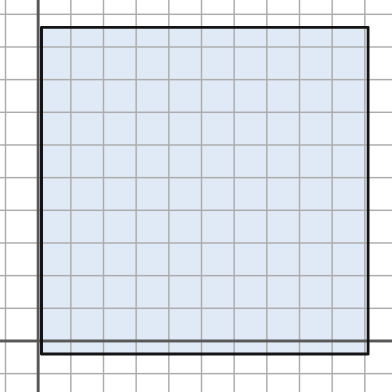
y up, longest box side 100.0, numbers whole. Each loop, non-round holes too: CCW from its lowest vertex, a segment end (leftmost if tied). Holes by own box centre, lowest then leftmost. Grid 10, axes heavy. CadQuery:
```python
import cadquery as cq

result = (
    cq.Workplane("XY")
    .moveTo(1.0, -4.0)
    .lineTo(101.0, -4.0)
    .lineTo(101.0, 96.0)
    .lineTo(1.0, 96.0)
    .close()
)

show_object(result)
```